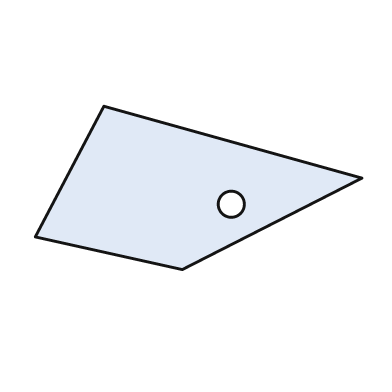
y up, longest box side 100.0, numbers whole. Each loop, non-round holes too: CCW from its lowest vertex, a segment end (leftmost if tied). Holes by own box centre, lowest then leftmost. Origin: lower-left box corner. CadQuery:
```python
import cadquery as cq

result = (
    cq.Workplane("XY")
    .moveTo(45.0, 0.0)
    .lineTo(100.0, 28.0)
    .lineTo(21.0, 50.0)
    .lineTo(0.0, 10.0)
    .close()
    .moveTo(60.0, 20.0)
    .circle(4.0)
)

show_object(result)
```